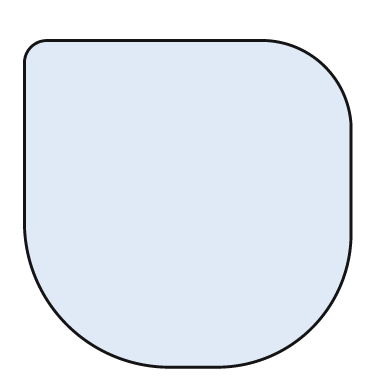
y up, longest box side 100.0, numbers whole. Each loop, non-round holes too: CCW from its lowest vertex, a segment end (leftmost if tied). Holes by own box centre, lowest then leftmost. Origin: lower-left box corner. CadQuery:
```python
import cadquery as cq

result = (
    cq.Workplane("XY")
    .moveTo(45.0, 0.0)
    .lineTo(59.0, 0.0)
    .threePointArc((88.0, 12.0), (100.0, 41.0))
    .lineTo(100.0, 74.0)
    .threePointArc((92.0, 92.0), (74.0, 100.0))
    .lineTo(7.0, 100.0)
    .threePointArc((2.0, 98.0), (0.0, 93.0))
    .lineTo(0.0, 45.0)
    .threePointArc((13.0, 13.0), (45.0, 0.0))
    .close()
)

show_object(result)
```